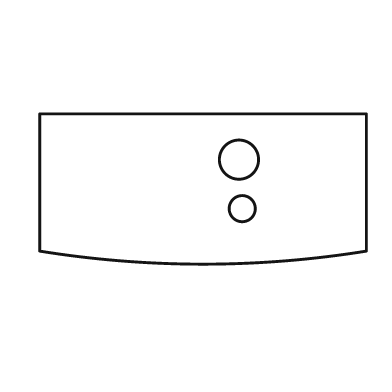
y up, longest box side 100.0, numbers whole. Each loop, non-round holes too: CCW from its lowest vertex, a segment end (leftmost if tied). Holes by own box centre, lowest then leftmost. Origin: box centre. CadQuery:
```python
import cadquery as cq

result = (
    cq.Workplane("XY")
    .moveTo(-50.0, -19.0)
    .threePointArc((0.0, -23.0), (50.0, -19.0))
    .lineTo(50.0, 23.0)
    .lineTo(-50.0, 23.0)
    .close()
    .moveTo(12.0, -6.0)
    .circle(4.0)
    .moveTo(11.0, 9.0)
    .circle(6.0)
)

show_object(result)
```